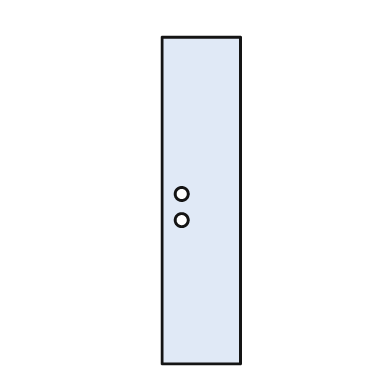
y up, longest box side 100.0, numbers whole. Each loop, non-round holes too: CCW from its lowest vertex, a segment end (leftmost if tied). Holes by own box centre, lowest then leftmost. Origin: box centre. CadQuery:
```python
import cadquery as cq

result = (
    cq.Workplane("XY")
    .moveTo(-12.0, -50.0)
    .lineTo(12.0, -50.0)
    .lineTo(12.0, 50.0)
    .lineTo(-12.0, 50.0)
    .close()
    .moveTo(-6.0, -6.0)
    .circle(2.0)
    .moveTo(-6.0, 2.0)
    .circle(2.0)
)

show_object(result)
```